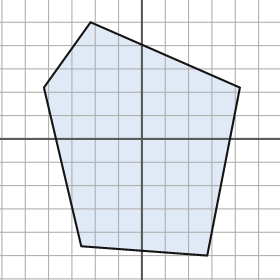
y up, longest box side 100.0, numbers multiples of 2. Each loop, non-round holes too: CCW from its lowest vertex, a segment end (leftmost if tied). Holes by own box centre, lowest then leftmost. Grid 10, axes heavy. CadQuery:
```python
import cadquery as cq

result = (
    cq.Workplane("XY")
    .moveTo(28.0, -50.0)
    .lineTo(42.0, 22.0)
    .lineTo(-22.0, 50.0)
    .lineTo(-42.0, 22.0)
    .lineTo(-26.0, -46.0)
    .close()
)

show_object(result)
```